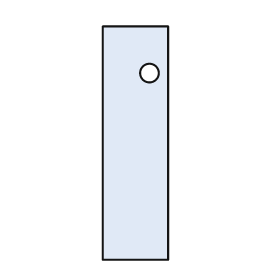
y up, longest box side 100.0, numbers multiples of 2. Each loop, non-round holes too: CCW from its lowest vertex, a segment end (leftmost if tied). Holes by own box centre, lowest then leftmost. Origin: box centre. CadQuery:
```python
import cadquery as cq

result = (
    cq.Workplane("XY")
    .moveTo(-14.0, -50.0)
    .lineTo(14.0, -50.0)
    .lineTo(14.0, 50.0)
    .lineTo(-14.0, 50.0)
    .close()
    .moveTo(6.0, 30.0)
    .circle(4.0)
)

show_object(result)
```